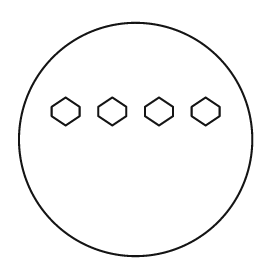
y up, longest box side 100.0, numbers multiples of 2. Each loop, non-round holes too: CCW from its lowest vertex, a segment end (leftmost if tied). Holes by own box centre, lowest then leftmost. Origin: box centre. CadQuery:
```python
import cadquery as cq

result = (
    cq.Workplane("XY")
    .moveTo(0.0, 0.0)
    .circle(50.0)
    .moveTo(-30.0, 6.0)
    .lineTo(-24.0, 10.0)
    .lineTo(-24.0, 14.0)
    .lineTo(-30.0, 18.0)
    .lineTo(-36.0, 14.0)
    .lineTo(-36.0, 10.0)
    .close()
    .moveTo(-10.0, 6.0)
    .lineTo(-4.0, 10.0)
    .lineTo(-4.0, 14.0)
    .lineTo(-10.0, 18.0)
    .lineTo(-16.0, 14.0)
    .lineTo(-16.0, 10.0)
    .close()
    .moveTo(10.0, 6.0)
    .lineTo(16.0, 10.0)
    .lineTo(16.0, 14.0)
    .lineTo(10.0, 18.0)
    .lineTo(4.0, 14.0)
    .lineTo(4.0, 10.0)
    .close()
    .moveTo(30.0, 6.0)
    .lineTo(36.0, 10.0)
    .lineTo(36.0, 14.0)
    .lineTo(30.0, 18.0)
    .lineTo(24.0, 14.0)
    .lineTo(24.0, 10.0)
    .close()
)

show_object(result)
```